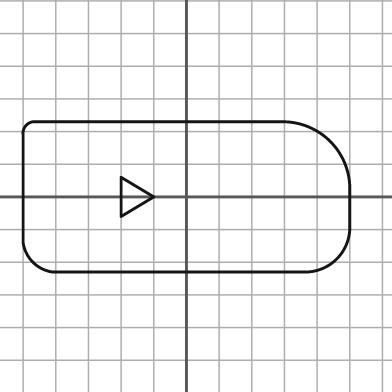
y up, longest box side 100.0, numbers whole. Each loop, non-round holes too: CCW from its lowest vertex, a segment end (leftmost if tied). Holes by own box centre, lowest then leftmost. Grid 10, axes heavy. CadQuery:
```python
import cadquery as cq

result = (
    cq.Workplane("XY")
    .moveTo(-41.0, -23.0)
    .lineTo(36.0, -23.0)
    .threePointArc((46.0, -19.0), (50.0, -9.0))
    .lineTo(50.0, 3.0)
    .threePointArc((44.0, 17.0), (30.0, 23.0))
    .lineTo(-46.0, 23.0)
    .threePointArc((-49.0, 22.0), (-50.0, 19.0))
    .lineTo(-50.0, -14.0)
    .threePointArc((-47.0, -20.0), (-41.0, -23.0))
    .close()
    .moveTo(-20.0, -6.0)
    .lineTo(-10.0, 0.0)
    .lineTo(-20.0, 6.0)
    .close()
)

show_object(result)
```